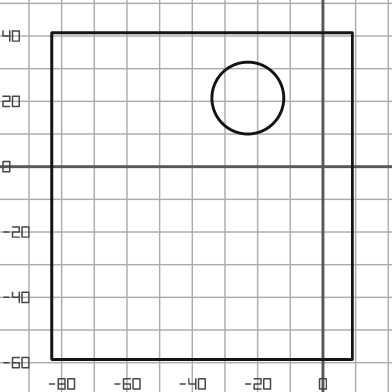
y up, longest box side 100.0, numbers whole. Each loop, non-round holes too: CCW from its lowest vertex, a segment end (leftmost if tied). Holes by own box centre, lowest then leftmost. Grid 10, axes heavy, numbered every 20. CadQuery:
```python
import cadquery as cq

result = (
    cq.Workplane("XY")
    .moveTo(-83.0, -59.0)
    .lineTo(9.0, -59.0)
    .lineTo(9.0, 41.0)
    .lineTo(-83.0, 41.0)
    .close()
    .moveTo(-23.0, 21.0)
    .circle(11.0)
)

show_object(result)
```